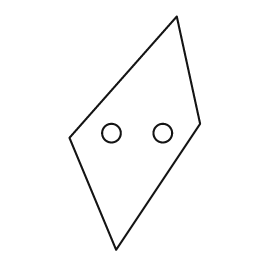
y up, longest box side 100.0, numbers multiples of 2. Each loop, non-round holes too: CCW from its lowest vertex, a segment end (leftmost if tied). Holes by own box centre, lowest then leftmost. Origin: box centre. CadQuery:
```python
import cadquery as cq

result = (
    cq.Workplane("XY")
    .moveTo(-8.0, -50.0)
    .lineTo(28.0, 4.0)
    .lineTo(18.0, 50.0)
    .lineTo(-28.0, -2.0)
    .close()
    .moveTo(-10.0, 0.0)
    .circle(4.0)
    .moveTo(12.0, 0.0)
    .circle(4.0)
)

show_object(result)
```